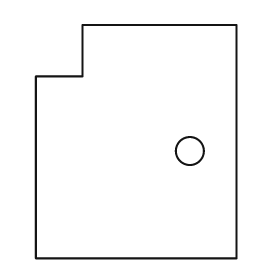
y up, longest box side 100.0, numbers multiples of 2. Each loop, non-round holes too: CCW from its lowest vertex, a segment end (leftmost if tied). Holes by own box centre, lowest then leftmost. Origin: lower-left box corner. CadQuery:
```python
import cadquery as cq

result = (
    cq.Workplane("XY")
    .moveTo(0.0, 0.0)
    .lineTo(86.0, 0.0)
    .lineTo(86.0, 100.0)
    .lineTo(20.0, 100.0)
    .lineTo(20.0, 78.0)
    .lineTo(0.0, 78.0)
    .close()
    .moveTo(66.0, 46.0)
    .circle(6.0)
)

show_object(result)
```